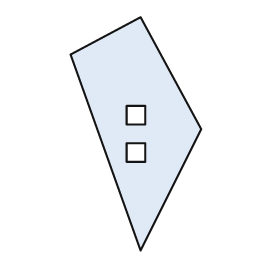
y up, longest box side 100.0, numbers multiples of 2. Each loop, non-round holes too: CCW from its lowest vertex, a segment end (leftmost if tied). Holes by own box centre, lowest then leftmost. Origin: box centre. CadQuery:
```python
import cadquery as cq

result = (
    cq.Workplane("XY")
    .moveTo(2.0, -50.0)
    .lineTo(28.0, 2.0)
    .lineTo(2.0, 50.0)
    .lineTo(-28.0, 34.0)
    .close()
    .moveTo(-4.0, -12.0)
    .lineTo(4.0, -12.0)
    .lineTo(4.0, -4.0)
    .lineTo(-4.0, -4.0)
    .close()
    .moveTo(-4.0, 4.0)
    .lineTo(4.0, 4.0)
    .lineTo(4.0, 12.0)
    .lineTo(-4.0, 12.0)
    .close()
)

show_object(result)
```